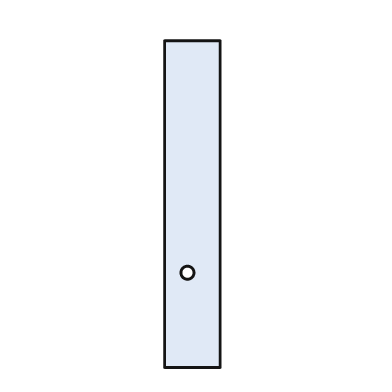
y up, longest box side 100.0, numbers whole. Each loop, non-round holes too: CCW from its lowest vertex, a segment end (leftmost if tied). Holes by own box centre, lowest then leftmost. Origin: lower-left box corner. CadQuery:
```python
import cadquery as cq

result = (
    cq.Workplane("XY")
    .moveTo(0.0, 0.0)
    .lineTo(17.0, 0.0)
    .lineTo(17.0, 100.0)
    .lineTo(0.0, 100.0)
    .close()
    .moveTo(7.0, 29.0)
    .circle(2.0)
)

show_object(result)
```